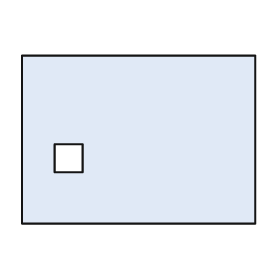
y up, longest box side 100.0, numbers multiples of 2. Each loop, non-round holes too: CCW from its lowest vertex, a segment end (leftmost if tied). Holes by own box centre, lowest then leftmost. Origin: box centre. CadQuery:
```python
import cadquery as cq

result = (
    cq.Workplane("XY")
    .moveTo(-50.0, -36.0)
    .lineTo(50.0, -36.0)
    .lineTo(50.0, 36.0)
    .lineTo(-50.0, 36.0)
    .close()
    .moveTo(-36.0, -14.0)
    .lineTo(-24.0, -14.0)
    .lineTo(-24.0, -2.0)
    .lineTo(-36.0, -2.0)
    .close()
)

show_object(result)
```